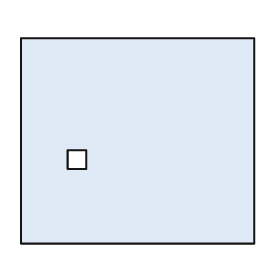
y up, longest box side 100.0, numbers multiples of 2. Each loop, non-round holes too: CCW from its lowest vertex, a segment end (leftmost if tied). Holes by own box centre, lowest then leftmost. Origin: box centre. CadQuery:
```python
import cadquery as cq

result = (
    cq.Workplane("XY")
    .moveTo(-50.0, -44.0)
    .lineTo(50.0, -44.0)
    .lineTo(50.0, 44.0)
    .lineTo(-50.0, 44.0)
    .close()
    .moveTo(-30.0, -12.0)
    .lineTo(-22.0, -12.0)
    .lineTo(-22.0, -4.0)
    .lineTo(-30.0, -4.0)
    .close()
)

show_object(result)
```